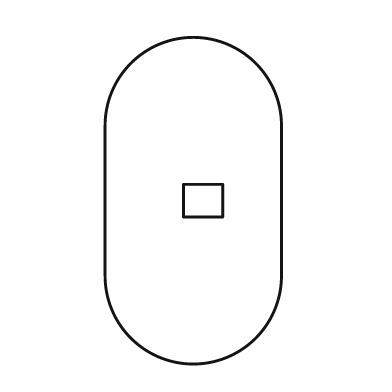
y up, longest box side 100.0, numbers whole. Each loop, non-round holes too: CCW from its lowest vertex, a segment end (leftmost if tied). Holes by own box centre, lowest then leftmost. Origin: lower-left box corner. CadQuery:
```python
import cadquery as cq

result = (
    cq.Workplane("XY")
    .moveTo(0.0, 27.0)
    .threePointArc((27.0, 0.0), (54.0, 27.0))
    .lineTo(54.0, 73.0)
    .threePointArc((27.0, 100.0), (0.0, 73.0))
    .close()
    .moveTo(24.0, 45.0)
    .lineTo(36.0, 45.0)
    .lineTo(36.0, 55.0)
    .lineTo(24.0, 55.0)
    .close()
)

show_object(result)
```